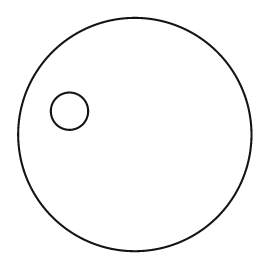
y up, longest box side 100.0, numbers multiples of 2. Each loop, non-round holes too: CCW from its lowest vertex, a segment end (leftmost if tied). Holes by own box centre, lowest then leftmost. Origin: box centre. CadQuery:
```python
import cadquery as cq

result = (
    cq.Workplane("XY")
    .moveTo(0.0, 0.0)
    .circle(50.0)
    .moveTo(-28.0, 10.0)
    .circle(8.0)
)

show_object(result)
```